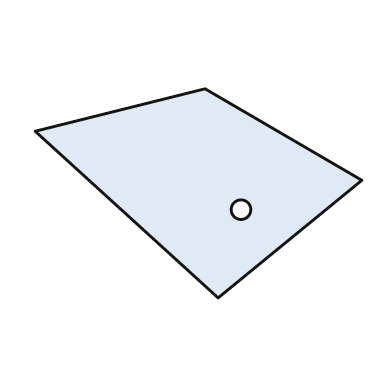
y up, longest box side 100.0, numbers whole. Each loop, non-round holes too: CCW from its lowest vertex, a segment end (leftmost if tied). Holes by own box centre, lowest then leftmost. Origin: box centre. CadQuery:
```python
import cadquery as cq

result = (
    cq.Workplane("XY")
    .moveTo(6.0, -32.0)
    .lineTo(50.0, 4.0)
    .lineTo(2.0, 32.0)
    .lineTo(-50.0, 19.0)
    .close()
    .moveTo(13.0, -5.0)
    .circle(3.0)
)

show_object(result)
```